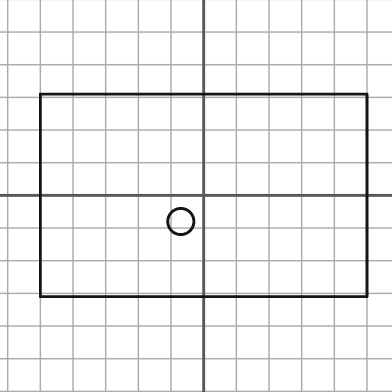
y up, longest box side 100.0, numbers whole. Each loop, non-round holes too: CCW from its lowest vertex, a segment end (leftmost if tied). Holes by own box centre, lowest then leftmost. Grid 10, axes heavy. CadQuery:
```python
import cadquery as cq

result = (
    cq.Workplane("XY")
    .moveTo(-50.0, -31.0)
    .lineTo(50.0, -31.0)
    .lineTo(50.0, 31.0)
    .lineTo(-50.0, 31.0)
    .close()
    .moveTo(-7.0, -8.0)
    .circle(4.0)
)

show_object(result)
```